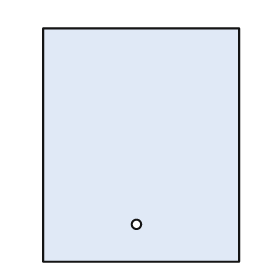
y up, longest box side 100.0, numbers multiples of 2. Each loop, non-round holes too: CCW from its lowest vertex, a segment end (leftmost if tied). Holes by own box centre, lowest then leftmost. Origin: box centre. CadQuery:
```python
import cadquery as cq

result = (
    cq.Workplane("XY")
    .moveTo(-42.0, -50.0)
    .lineTo(42.0, -50.0)
    .lineTo(42.0, 50.0)
    .lineTo(-42.0, 50.0)
    .close()
    .moveTo(-2.0, -34.0)
    .circle(2.0)
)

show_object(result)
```